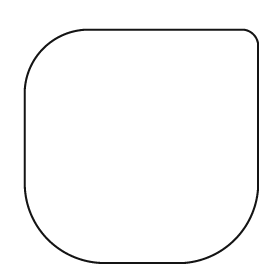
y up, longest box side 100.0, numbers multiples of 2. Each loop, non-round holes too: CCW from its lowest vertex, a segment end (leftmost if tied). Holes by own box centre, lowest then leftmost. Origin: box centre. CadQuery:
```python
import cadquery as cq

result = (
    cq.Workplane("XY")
    .moveTo(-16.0, -50.0)
    .lineTo(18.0, -50.0)
    .threePointArc((40.0, -40.0), (50.0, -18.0))
    .lineTo(50.0, 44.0)
    .threePointArc((48.0, 48.0), (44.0, 50.0))
    .lineTo(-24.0, 50.0)
    .threePointArc((-42.0, 42.0), (-50.0, 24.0))
    .lineTo(-50.0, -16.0)
    .threePointArc((-40.0, -40.0), (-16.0, -50.0))
    .close()
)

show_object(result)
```